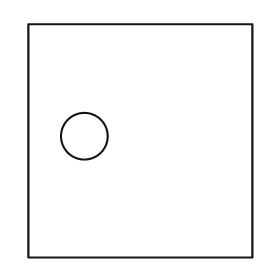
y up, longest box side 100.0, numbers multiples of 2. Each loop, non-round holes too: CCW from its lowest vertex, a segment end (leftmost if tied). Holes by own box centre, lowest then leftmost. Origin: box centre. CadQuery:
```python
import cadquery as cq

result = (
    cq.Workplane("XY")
    .moveTo(-48.0, -50.0)
    .lineTo(48.0, -50.0)
    .lineTo(48.0, 50.0)
    .lineTo(-48.0, 50.0)
    .close()
    .moveTo(-24.0, 2.0)
    .circle(10.0)
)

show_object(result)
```